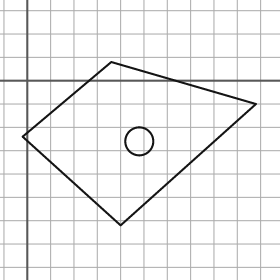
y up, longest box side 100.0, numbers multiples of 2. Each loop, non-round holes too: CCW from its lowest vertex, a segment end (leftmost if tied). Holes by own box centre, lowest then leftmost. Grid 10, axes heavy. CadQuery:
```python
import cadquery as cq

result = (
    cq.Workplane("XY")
    .moveTo(40.0, -62.0)
    .lineTo(98.0, -10.0)
    .lineTo(36.0, 8.0)
    .lineTo(-2.0, -24.0)
    .close()
    .moveTo(48.0, -26.0)
    .circle(6.0)
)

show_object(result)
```